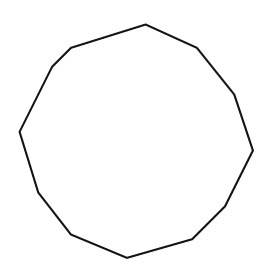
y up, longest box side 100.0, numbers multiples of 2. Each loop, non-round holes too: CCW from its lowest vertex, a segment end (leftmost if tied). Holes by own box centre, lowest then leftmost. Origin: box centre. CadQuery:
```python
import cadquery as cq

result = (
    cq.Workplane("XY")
    .moveTo(-4.0, -50.0)
    .lineTo(24.0, -42.0)
    .lineTo(38.0, -28.0)
    .lineTo(50.0, -4.0)
    .lineTo(42.0, 20.0)
    .lineTo(26.0, 40.0)
    .lineTo(4.0, 50.0)
    .lineTo(-28.0, 40.0)
    .lineTo(-36.0, 32.0)
    .lineTo(-50.0, 4.0)
    .lineTo(-42.0, -22.0)
    .lineTo(-28.0, -40.0)
    .close()
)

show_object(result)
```